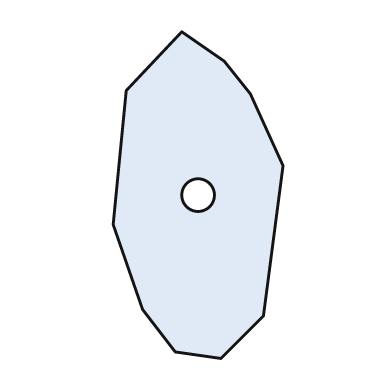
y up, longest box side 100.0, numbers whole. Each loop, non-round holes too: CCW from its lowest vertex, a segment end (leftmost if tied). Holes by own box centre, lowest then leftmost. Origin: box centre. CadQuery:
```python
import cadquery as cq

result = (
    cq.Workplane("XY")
    .moveTo(7.0, -50.0)
    .lineTo(20.0, -37.0)
    .lineTo(26.0, 9.0)
    .lineTo(16.0, 31.0)
    .lineTo(8.0, 41.0)
    .lineTo(-5.0, 50.0)
    .lineTo(-22.0, 32.0)
    .lineTo(-26.0, -9.0)
    .lineTo(-17.0, -35.0)
    .lineTo(-7.0, -48.0)
    .close()
    .moveTo(0.0, 0.0)
    .circle(5.0)
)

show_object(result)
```